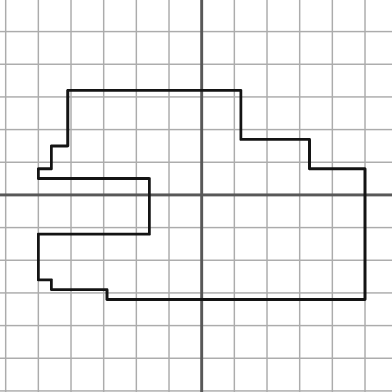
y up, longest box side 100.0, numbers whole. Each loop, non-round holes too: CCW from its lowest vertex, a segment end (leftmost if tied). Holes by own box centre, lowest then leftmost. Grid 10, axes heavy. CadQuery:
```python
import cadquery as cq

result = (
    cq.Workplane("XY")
    .moveTo(-29.0, -32.0)
    .lineTo(50.0, -32.0)
    .lineTo(50.0, 8.0)
    .lineTo(33.0, 8.0)
    .lineTo(33.0, 17.0)
    .lineTo(12.0, 17.0)
    .lineTo(12.0, 32.0)
    .lineTo(-41.0, 32.0)
    .lineTo(-41.0, 15.0)
    .lineTo(-46.0, 15.0)
    .lineTo(-46.0, 8.0)
    .lineTo(-50.0, 8.0)
    .lineTo(-50.0, 5.0)
    .lineTo(-16.0, 5.0)
    .lineTo(-16.0, -12.0)
    .lineTo(-50.0, -12.0)
    .lineTo(-50.0, -26.0)
    .lineTo(-46.0, -26.0)
    .lineTo(-46.0, -29.0)
    .lineTo(-29.0, -29.0)
    .close()
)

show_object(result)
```